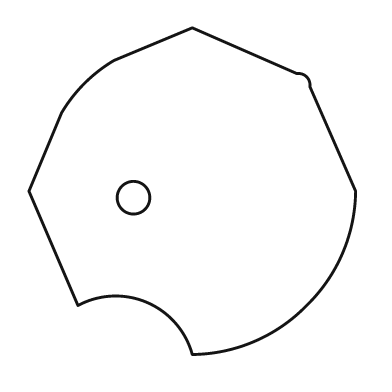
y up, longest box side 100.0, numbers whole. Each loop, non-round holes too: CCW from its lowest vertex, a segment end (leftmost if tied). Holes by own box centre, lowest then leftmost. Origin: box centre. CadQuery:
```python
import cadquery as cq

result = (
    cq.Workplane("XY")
    .moveTo(0.0, -50.0)
    .threePointArc((19.0, -46.0), (35.0, -35.0))
    .threePointArc((46.0, -19.0), (50.0, 0.0))
    .lineTo(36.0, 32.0)
    .threePointArc((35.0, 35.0), (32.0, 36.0))
    .lineTo(0.0, 50.0)
    .lineTo(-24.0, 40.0)
    .threePointArc((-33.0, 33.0), (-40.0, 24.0))
    .lineTo(-50.0, 0.0)
    .lineTo(-35.0, -35.0)
    .threePointArc((-14.0, -34.0), (0.0, -50.0))
    .close()
    .moveTo(-18.0, -2.0)
    .circle(5.0)
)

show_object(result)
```